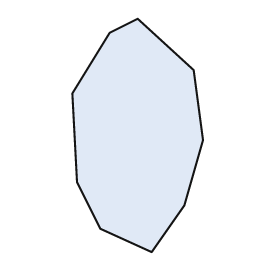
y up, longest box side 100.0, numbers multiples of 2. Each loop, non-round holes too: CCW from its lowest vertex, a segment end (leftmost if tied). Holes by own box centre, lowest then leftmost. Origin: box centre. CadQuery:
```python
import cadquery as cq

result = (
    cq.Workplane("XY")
    .moveTo(6.0, -50.0)
    .lineTo(20.0, -30.0)
    .lineTo(28.0, -2.0)
    .lineTo(24.0, 28.0)
    .lineTo(0.0, 50.0)
    .lineTo(-12.0, 44.0)
    .lineTo(-28.0, 18.0)
    .lineTo(-26.0, -20.0)
    .lineTo(-16.0, -40.0)
    .close()
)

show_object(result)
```